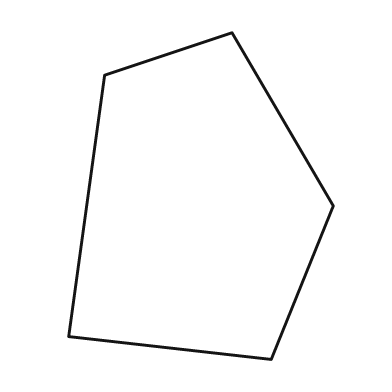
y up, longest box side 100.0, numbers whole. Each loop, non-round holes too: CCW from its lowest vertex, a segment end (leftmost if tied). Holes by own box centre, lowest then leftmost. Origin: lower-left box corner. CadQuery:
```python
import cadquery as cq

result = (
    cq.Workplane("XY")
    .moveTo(62.0, 0.0)
    .lineTo(81.0, 47.0)
    .lineTo(50.0, 100.0)
    .lineTo(11.0, 87.0)
    .lineTo(0.0, 7.0)
    .close()
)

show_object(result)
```